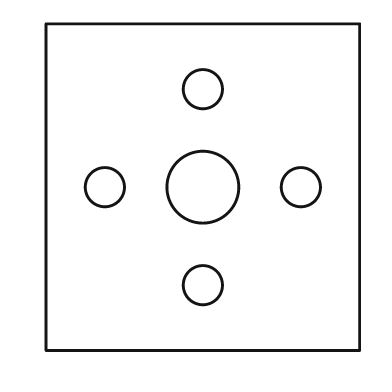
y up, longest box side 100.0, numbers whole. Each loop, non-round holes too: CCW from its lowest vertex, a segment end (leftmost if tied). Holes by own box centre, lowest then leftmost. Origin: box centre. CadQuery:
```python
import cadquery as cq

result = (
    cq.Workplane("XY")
    .moveTo(-48.0, -50.0)
    .lineTo(48.0, -50.0)
    .lineTo(48.0, 50.0)
    .lineTo(-48.0, 50.0)
    .close()
    .moveTo(0.0, -30.0)
    .circle(6.0)
    .moveTo(-30.0, 0.0)
    .circle(6.0)
    .moveTo(0.0, 0.0)
    .circle(11.0)
    .moveTo(30.0, 0.0)
    .circle(6.0)
    .moveTo(0.0, 30.0)
    .circle(6.0)
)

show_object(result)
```